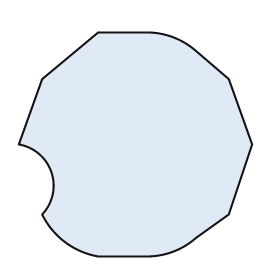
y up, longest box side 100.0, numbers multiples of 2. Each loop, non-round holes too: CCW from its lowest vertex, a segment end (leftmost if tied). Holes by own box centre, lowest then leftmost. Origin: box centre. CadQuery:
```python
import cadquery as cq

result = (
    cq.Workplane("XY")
    .moveTo(-16.0, -48.0)
    .lineTo(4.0, -48.0)
    .threePointArc((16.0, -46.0), (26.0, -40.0))
    .lineTo(40.0, -30.0)
    .lineTo(50.0, 0.0)
    .lineTo(40.0, 28.0)
    .lineTo(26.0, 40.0)
    .threePointArc((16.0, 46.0), (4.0, 48.0))
    .lineTo(-16.0, 48.0)
    .lineTo(-40.0, 28.0)
    .lineTo(-50.0, 0.0)
    .threePointArc((-36.0, -12.0), (-40.0, -30.0))
    .threePointArc((-30.0, -42.0), (-16.0, -48.0))
    .close()
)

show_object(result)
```